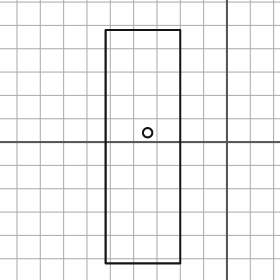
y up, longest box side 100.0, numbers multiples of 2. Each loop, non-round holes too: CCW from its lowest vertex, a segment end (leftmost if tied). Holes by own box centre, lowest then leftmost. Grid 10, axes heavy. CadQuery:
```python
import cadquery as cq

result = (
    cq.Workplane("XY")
    .moveTo(-52.0, -52.0)
    .lineTo(-20.0, -52.0)
    .lineTo(-20.0, 48.0)
    .lineTo(-52.0, 48.0)
    .close()
    .moveTo(-34.0, 4.0)
    .circle(2.0)
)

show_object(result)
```